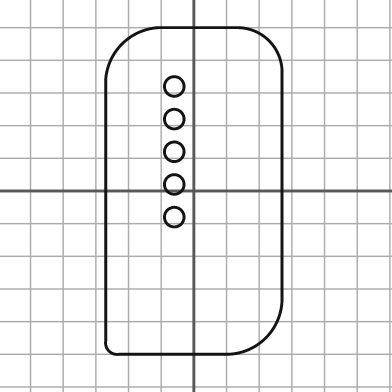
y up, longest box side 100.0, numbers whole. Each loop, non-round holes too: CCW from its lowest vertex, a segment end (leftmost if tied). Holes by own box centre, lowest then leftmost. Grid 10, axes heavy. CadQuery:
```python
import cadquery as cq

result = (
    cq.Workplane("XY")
    .moveTo(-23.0, -50.0)
    .lineTo(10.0, -50.0)
    .threePointArc((22.0, -45.0), (27.0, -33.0))
    .lineTo(27.0, 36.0)
    .threePointArc((23.0, 46.0), (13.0, 50.0))
    .lineTo(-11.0, 50.0)
    .threePointArc((-22.0, 45.0), (-27.0, 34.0))
    .lineTo(-27.0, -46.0)
    .threePointArc((-26.0, -49.0), (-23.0, -50.0))
    .close()
    .moveTo(-6.0, -8.0)
    .circle(3.0)
    .moveTo(-6.0, 2.0)
    .circle(3.0)
    .moveTo(-6.0, 12.0)
    .circle(3.0)
    .moveTo(-6.0, 22.0)
    .circle(3.0)
    .moveTo(-6.0, 32.0)
    .circle(3.0)
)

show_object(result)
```